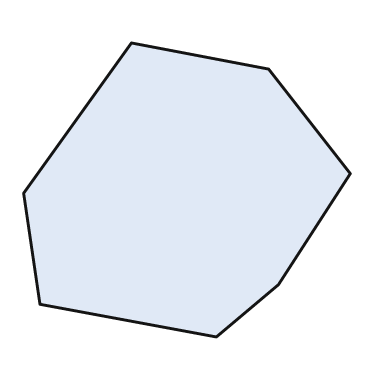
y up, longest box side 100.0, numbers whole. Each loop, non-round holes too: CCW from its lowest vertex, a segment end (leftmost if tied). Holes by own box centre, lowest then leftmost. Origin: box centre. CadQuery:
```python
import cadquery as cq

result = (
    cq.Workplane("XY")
    .moveTo(9.0, -45.0)
    .lineTo(28.0, -29.0)
    .lineTo(50.0, 5.0)
    .lineTo(25.0, 37.0)
    .lineTo(-17.0, 45.0)
    .lineTo(-50.0, -1.0)
    .lineTo(-45.0, -35.0)
    .close()
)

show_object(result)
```